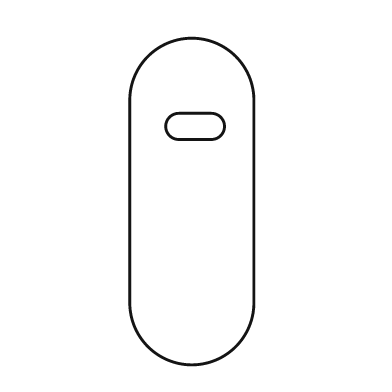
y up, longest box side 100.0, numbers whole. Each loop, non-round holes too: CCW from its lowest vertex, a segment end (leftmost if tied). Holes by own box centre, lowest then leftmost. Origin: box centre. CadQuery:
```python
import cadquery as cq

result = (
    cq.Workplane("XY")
    .moveTo(-19.0, -31.0)
    .threePointArc((0.0, -50.0), (19.0, -31.0))
    .lineTo(19.0, 31.0)
    .threePointArc((0.0, 50.0), (-19.0, 31.0))
    .close()
    .moveTo(-4.0, 19.0)
    .lineTo(6.0, 19.0)
    .threePointArc((10.0, 23.0), (6.0, 27.0))
    .lineTo(-4.0, 27.0)
    .threePointArc((-8.0, 23.0), (-4.0, 19.0))
    .close()
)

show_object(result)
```